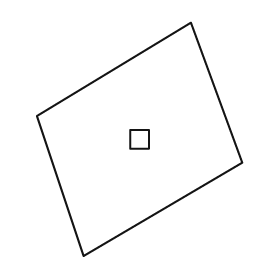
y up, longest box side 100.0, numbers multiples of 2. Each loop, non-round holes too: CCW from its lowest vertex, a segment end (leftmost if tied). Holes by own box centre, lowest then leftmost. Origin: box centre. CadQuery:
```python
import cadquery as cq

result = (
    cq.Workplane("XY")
    .moveTo(-24.0, -50.0)
    .lineTo(44.0, -10.0)
    .lineTo(22.0, 50.0)
    .lineTo(-44.0, 10.0)
    .close()
    .moveTo(-4.0, -4.0)
    .lineTo(4.0, -4.0)
    .lineTo(4.0, 4.0)
    .lineTo(-4.0, 4.0)
    .close()
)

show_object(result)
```